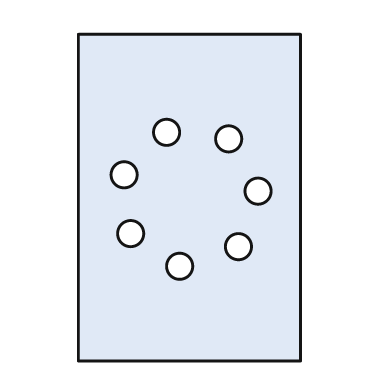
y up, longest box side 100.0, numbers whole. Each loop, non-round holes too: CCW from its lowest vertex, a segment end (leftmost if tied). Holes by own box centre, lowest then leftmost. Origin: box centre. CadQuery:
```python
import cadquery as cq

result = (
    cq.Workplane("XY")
    .moveTo(-34.0, -50.0)
    .lineTo(34.0, -50.0)
    .lineTo(34.0, 50.0)
    .lineTo(-34.0, 50.0)
    .close()
    .moveTo(-3.0, -21.0)
    .circle(4.0)
    .moveTo(15.0, -15.0)
    .circle(4.0)
    .moveTo(-18.0, -11.0)
    .circle(4.0)
    .moveTo(21.0, 2.0)
    .circle(4.0)
    .moveTo(-20.0, 7.0)
    .circle(4.0)
    .moveTo(12.0, 18.0)
    .circle(4.0)
    .moveTo(-7.0, 20.0)
    .circle(4.0)
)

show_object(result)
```